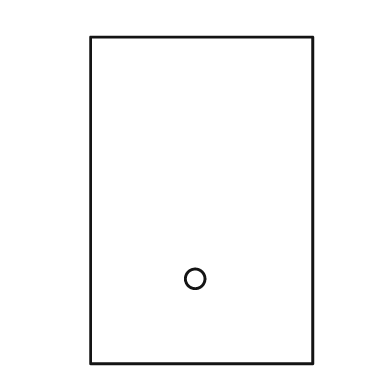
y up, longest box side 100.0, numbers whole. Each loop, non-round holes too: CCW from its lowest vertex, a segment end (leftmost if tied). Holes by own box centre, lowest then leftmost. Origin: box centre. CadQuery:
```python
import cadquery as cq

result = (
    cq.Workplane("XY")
    .moveTo(-34.0, -50.0)
    .lineTo(34.0, -50.0)
    .lineTo(34.0, 50.0)
    .lineTo(-34.0, 50.0)
    .close()
    .moveTo(-2.0, -24.0)
    .circle(3.0)
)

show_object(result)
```